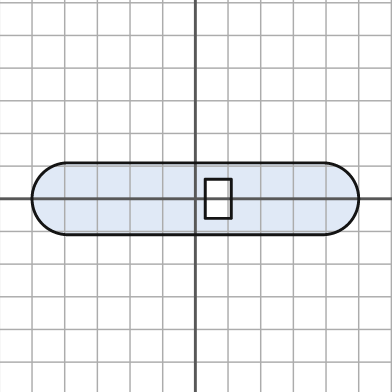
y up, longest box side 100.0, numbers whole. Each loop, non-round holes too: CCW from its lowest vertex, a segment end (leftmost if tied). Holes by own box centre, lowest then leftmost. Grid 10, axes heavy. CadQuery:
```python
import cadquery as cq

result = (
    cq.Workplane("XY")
    .moveTo(-39.0, -11.0)
    .lineTo(39.0, -11.0)
    .threePointArc((50.0, 0.0), (39.0, 11.0))
    .lineTo(-39.0, 11.0)
    .threePointArc((-50.0, 0.0), (-39.0, -11.0))
    .close()
    .moveTo(3.0, -6.0)
    .lineTo(11.0, -6.0)
    .lineTo(11.0, 6.0)
    .lineTo(3.0, 6.0)
    .close()
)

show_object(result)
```